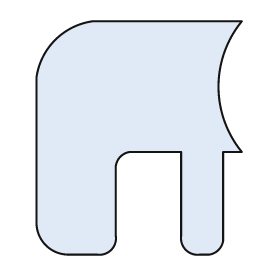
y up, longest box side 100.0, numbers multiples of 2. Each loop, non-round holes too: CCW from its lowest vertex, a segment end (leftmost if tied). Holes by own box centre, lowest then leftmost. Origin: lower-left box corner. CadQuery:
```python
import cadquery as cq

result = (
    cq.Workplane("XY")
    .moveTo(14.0, 0.0)
    .lineTo(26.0, 0.0)
    .threePointArc((32.0, 2.0), (34.0, 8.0))
    .lineTo(34.0, 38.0)
    .threePointArc((36.0, 42.0), (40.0, 44.0))
    .lineTo(62.0, 44.0)
    .lineTo(62.0, 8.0)
    .threePointArc((64.0, 2.0), (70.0, 0.0))
    .lineTo(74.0, 0.0)
    .threePointArc((78.0, 2.0), (80.0, 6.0))
    .lineTo(80.0, 44.0)
    .lineTo(88.0, 44.0)
    .threePointArc((78.0, 72.0), (88.0, 100.0))
    .lineTo(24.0, 100.0)
    .threePointArc((8.0, 92.0), (0.0, 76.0))
    .lineTo(0.0, 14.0)
    .threePointArc((4.0, 4.0), (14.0, 0.0))
    .close()
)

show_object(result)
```